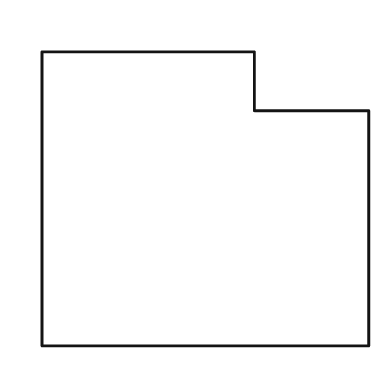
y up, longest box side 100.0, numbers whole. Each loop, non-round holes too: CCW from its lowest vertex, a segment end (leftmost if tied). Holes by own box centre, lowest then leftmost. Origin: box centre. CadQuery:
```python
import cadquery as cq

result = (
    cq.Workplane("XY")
    .moveTo(-50.0, -45.0)
    .lineTo(50.0, -45.0)
    .lineTo(50.0, 27.0)
    .lineTo(15.0, 27.0)
    .lineTo(15.0, 45.0)
    .lineTo(-50.0, 45.0)
    .close()
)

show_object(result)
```